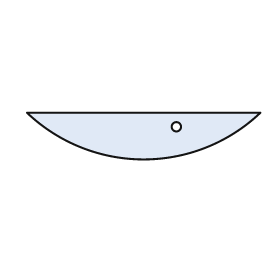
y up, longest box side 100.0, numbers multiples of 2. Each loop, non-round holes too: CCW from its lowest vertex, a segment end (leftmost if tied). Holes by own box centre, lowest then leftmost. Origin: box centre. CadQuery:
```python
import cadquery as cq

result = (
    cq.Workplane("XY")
    .moveTo(-50.0, 10.0)
    .threePointArc((0.0, -10.0), (50.0, 10.0))
    .close()
    .moveTo(14.0, 4.0)
    .circle(2.0)
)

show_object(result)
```